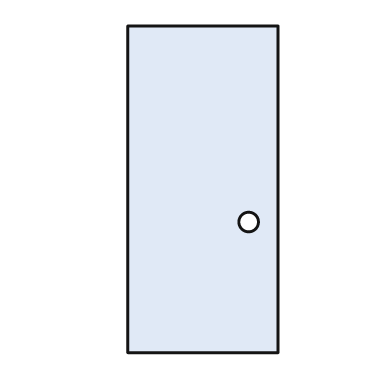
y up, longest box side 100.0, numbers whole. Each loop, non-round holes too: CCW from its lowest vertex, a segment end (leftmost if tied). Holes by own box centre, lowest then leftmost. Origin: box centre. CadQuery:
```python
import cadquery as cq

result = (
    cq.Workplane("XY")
    .moveTo(-23.0, -50.0)
    .lineTo(23.0, -50.0)
    .lineTo(23.0, 50.0)
    .lineTo(-23.0, 50.0)
    .close()
    .moveTo(14.0, -10.0)
    .circle(3.0)
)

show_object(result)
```